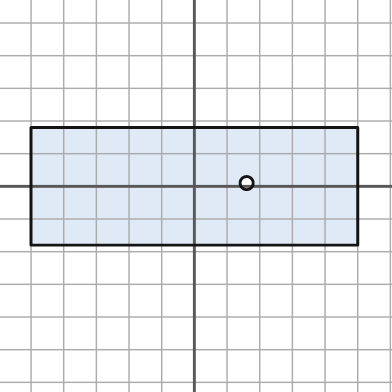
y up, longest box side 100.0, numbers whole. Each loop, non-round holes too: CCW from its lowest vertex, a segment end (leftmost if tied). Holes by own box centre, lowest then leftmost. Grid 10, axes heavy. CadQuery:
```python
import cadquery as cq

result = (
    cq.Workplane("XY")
    .moveTo(-50.0, -18.0)
    .lineTo(50.0, -18.0)
    .lineTo(50.0, 18.0)
    .lineTo(-50.0, 18.0)
    .close()
    .moveTo(16.0, 1.0)
    .circle(2.0)
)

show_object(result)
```